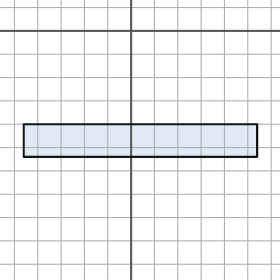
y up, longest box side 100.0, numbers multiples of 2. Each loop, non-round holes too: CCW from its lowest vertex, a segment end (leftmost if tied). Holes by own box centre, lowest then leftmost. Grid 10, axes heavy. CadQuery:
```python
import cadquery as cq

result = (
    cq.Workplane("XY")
    .moveTo(-46.0, -54.0)
    .lineTo(54.0, -54.0)
    .lineTo(54.0, -40.0)
    .lineTo(-46.0, -40.0)
    .close()
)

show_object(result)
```